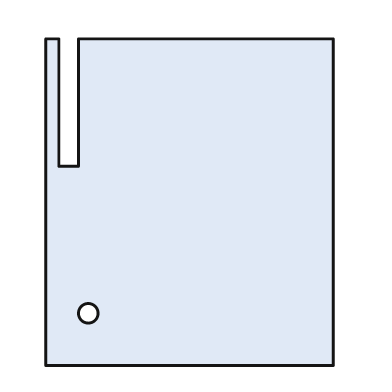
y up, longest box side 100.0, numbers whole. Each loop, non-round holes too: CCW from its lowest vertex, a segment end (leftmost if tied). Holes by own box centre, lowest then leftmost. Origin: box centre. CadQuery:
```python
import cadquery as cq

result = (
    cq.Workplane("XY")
    .moveTo(-44.0, -50.0)
    .lineTo(44.0, -50.0)
    .lineTo(44.0, 50.0)
    .lineTo(-34.0, 50.0)
    .lineTo(-34.0, 11.0)
    .lineTo(-40.0, 11.0)
    .lineTo(-40.0, 50.0)
    .lineTo(-44.0, 50.0)
    .close()
    .moveTo(-31.0, -34.0)
    .circle(3.0)
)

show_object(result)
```